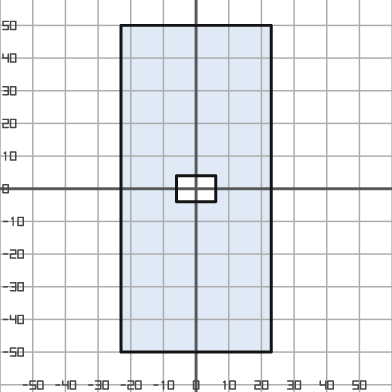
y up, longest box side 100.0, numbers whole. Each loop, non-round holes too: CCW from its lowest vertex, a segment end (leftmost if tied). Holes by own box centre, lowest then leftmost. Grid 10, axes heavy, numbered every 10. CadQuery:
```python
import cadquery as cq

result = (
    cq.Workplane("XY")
    .moveTo(-23.0, -50.0)
    .lineTo(23.0, -50.0)
    .lineTo(23.0, 50.0)
    .lineTo(-23.0, 50.0)
    .close()
    .moveTo(-6.0, -4.0)
    .lineTo(6.0, -4.0)
    .lineTo(6.0, 4.0)
    .lineTo(-6.0, 4.0)
    .close()
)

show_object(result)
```